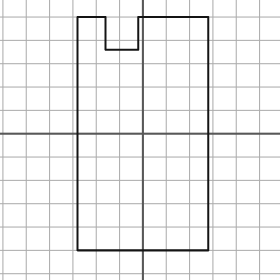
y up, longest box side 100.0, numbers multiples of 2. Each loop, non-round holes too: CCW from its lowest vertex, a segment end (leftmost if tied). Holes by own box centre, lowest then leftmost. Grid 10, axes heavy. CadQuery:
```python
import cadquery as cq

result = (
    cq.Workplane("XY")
    .moveTo(-28.0, -50.0)
    .lineTo(28.0, -50.0)
    .lineTo(28.0, 50.0)
    .lineTo(-2.0, 50.0)
    .lineTo(-2.0, 36.0)
    .lineTo(-16.0, 36.0)
    .lineTo(-16.0, 50.0)
    .lineTo(-28.0, 50.0)
    .close()
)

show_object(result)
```